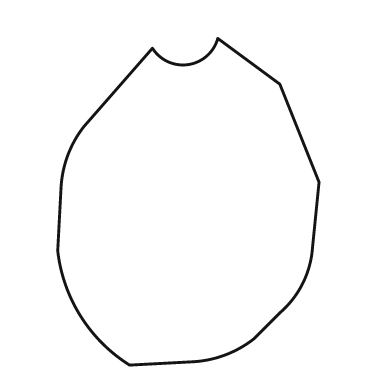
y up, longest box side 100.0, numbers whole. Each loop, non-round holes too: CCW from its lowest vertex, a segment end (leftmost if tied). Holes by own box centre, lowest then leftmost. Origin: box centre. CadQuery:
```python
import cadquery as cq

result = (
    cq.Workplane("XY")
    .moveTo(-18.0, -50.0)
    .lineTo(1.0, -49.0)
    .threePointArc((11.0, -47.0), (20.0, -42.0))
    .lineTo(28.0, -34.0)
    .threePointArc((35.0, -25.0), (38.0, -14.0))
    .lineTo(40.0, 6.0)
    .lineTo(28.0, 36.0)
    .lineTo(9.0, 50.0)
    .threePointArc((0.0, 42.0), (-11.0, 47.0))
    .lineTo(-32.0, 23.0)
    .threePointArc((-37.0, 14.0), (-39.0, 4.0))
    .lineTo(-40.0, -15.0)
    .threePointArc((-33.0, -35.0), (-18.0, -50.0))
    .close()
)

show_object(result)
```